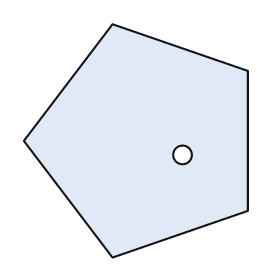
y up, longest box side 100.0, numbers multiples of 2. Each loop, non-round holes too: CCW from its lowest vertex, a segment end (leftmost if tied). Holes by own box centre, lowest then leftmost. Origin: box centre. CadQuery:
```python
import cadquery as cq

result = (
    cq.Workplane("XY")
    .moveTo(-10.0, -50.0)
    .lineTo(48.0, -30.0)
    .lineTo(48.0, 30.0)
    .lineTo(-10.0, 50.0)
    .lineTo(-48.0, 0.0)
    .close()
    .moveTo(20.0, -6.0)
    .circle(4.0)
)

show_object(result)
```